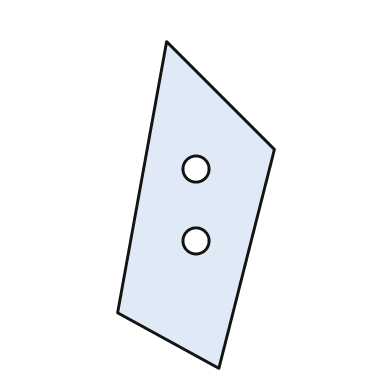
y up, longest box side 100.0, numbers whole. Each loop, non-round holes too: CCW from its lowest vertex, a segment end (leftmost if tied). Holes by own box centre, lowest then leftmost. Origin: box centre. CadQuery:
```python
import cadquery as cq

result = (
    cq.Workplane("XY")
    .moveTo(7.0, -50.0)
    .lineTo(24.0, 17.0)
    .lineTo(-9.0, 50.0)
    .lineTo(-24.0, -33.0)
    .close()
    .moveTo(0.0, -11.0)
    .circle(4.0)
    .moveTo(0.0, 11.0)
    .circle(4.0)
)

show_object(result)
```